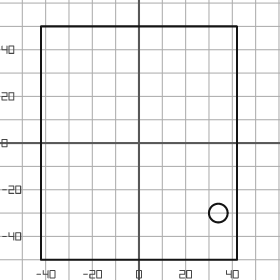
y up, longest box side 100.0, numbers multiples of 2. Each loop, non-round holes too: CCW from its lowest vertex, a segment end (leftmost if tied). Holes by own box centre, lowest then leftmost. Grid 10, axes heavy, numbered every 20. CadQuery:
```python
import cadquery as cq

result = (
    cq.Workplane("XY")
    .moveTo(-42.0, -50.0)
    .lineTo(42.0, -50.0)
    .lineTo(42.0, 50.0)
    .lineTo(-42.0, 50.0)
    .close()
    .moveTo(34.0, -30.0)
    .circle(4.0)
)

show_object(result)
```